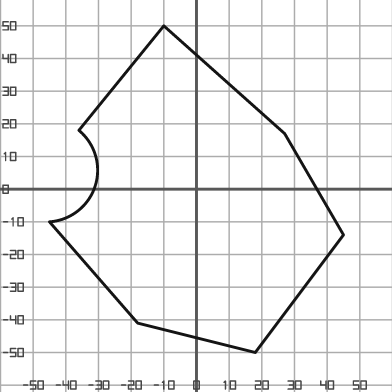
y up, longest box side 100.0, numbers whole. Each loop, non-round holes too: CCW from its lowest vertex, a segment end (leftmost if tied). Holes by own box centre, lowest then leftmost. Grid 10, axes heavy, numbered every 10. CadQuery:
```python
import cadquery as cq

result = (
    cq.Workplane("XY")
    .moveTo(18.0, -50.0)
    .lineTo(45.0, -14.0)
    .lineTo(27.0, 17.0)
    .lineTo(-10.0, 50.0)
    .lineTo(-36.0, 18.0)
    .threePointArc((-31.0, 1.0), (-45.0, -10.0))
    .lineTo(-18.0, -41.0)
    .close()
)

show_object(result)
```